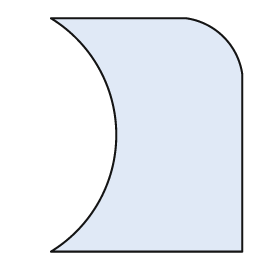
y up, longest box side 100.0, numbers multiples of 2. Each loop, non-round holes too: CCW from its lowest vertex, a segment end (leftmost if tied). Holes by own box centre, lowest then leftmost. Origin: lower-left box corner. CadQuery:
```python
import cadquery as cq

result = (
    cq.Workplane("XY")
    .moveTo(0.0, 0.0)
    .lineTo(82.0, 0.0)
    .lineTo(82.0, 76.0)
    .threePointArc((74.0, 92.0), (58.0, 100.0))
    .lineTo(0.0, 100.0)
    .threePointArc((28.0, 50.0), (0.0, 0.0))
    .close()
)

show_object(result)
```